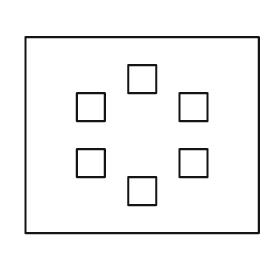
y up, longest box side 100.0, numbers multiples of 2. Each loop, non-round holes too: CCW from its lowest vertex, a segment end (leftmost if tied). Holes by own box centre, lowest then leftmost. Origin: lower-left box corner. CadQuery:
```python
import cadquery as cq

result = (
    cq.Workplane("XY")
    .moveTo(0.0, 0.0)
    .lineTo(100.0, 0.0)
    .lineTo(100.0, 84.0)
    .lineTo(0.0, 84.0)
    .close()
    .moveTo(44.0, 12.0)
    .lineTo(56.0, 12.0)
    .lineTo(56.0, 24.0)
    .lineTo(44.0, 24.0)
    .close()
    .moveTo(22.0, 24.0)
    .lineTo(34.0, 24.0)
    .lineTo(34.0, 36.0)
    .lineTo(22.0, 36.0)
    .close()
    .moveTo(66.0, 24.0)
    .lineTo(78.0, 24.0)
    .lineTo(78.0, 36.0)
    .lineTo(66.0, 36.0)
    .close()
    .moveTo(22.0, 48.0)
    .lineTo(34.0, 48.0)
    .lineTo(34.0, 60.0)
    .lineTo(22.0, 60.0)
    .close()
    .moveTo(66.0, 48.0)
    .lineTo(78.0, 48.0)
    .lineTo(78.0, 60.0)
    .lineTo(66.0, 60.0)
    .close()
    .moveTo(44.0, 60.0)
    .lineTo(56.0, 60.0)
    .lineTo(56.0, 72.0)
    .lineTo(44.0, 72.0)
    .close()
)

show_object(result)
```